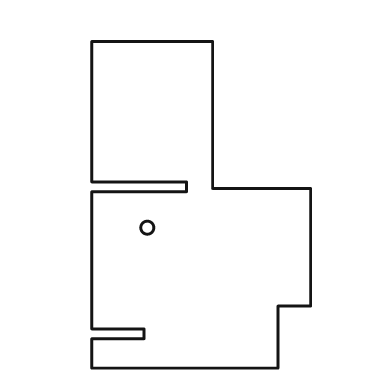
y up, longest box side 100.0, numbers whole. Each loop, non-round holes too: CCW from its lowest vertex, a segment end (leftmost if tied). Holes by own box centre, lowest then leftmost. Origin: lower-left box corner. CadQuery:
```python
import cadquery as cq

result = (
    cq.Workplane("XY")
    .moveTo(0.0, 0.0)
    .lineTo(57.0, 0.0)
    .lineTo(57.0, 19.0)
    .lineTo(67.0, 19.0)
    .lineTo(67.0, 55.0)
    .lineTo(37.0, 55.0)
    .lineTo(37.0, 100.0)
    .lineTo(0.0, 100.0)
    .lineTo(0.0, 57.0)
    .lineTo(29.0, 57.0)
    .lineTo(29.0, 54.0)
    .lineTo(0.0, 54.0)
    .lineTo(0.0, 12.0)
    .lineTo(16.0, 12.0)
    .lineTo(16.0, 9.0)
    .lineTo(0.0, 9.0)
    .close()
    .moveTo(17.0, 43.0)
    .circle(2.0)
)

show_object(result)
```